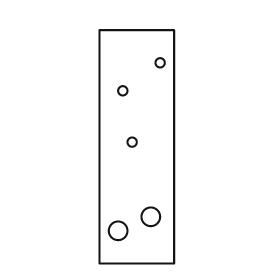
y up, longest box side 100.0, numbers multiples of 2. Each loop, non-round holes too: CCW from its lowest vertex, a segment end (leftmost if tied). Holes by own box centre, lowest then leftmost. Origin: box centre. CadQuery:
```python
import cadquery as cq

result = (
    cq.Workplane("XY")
    .moveTo(-16.0, -50.0)
    .lineTo(16.0, -50.0)
    .lineTo(16.0, 50.0)
    .lineTo(-16.0, 50.0)
    .close()
    .moveTo(-8.0, -36.0)
    .circle(4.0)
    .moveTo(6.0, -30.0)
    .circle(4.0)
    .moveTo(-2.0, 2.0)
    .circle(2.0)
    .moveTo(-6.0, 24.0)
    .circle(2.0)
    .moveTo(10.0, 36.0)
    .circle(2.0)
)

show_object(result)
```